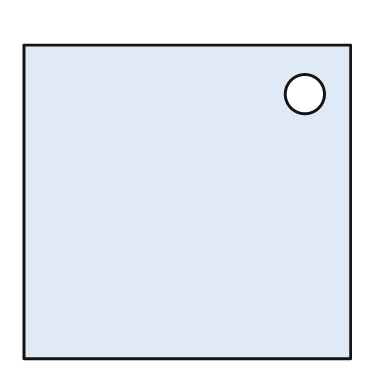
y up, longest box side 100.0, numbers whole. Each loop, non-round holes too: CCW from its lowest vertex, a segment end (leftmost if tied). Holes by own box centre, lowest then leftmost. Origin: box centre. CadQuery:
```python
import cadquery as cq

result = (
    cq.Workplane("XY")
    .moveTo(-50.0, -48.0)
    .lineTo(50.0, -48.0)
    .lineTo(50.0, 48.0)
    .lineTo(-50.0, 48.0)
    .close()
    .moveTo(36.0, 33.0)
    .circle(6.0)
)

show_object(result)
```